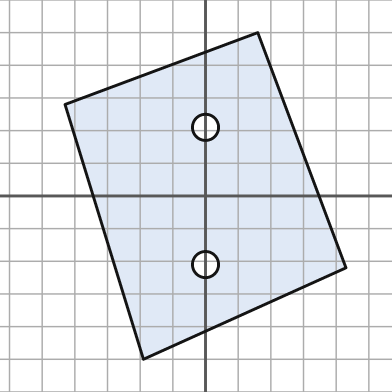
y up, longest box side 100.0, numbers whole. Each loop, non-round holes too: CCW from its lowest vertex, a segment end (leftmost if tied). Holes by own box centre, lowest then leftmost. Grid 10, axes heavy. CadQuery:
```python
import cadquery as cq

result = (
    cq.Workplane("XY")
    .moveTo(-19.0, -50.0)
    .lineTo(43.0, -22.0)
    .lineTo(16.0, 50.0)
    .lineTo(-43.0, 28.0)
    .close()
    .moveTo(0.0, -21.0)
    .circle(4.0)
    .moveTo(0.0, 21.0)
    .circle(4.0)
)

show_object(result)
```